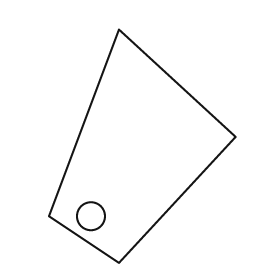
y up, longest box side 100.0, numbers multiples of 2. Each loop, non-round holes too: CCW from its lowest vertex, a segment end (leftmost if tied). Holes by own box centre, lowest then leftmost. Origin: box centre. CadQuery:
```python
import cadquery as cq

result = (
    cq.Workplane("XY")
    .moveTo(-10.0, -50.0)
    .lineTo(40.0, 4.0)
    .lineTo(-10.0, 50.0)
    .lineTo(-40.0, -30.0)
    .close()
    .moveTo(-22.0, -30.0)
    .circle(6.0)
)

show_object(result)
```